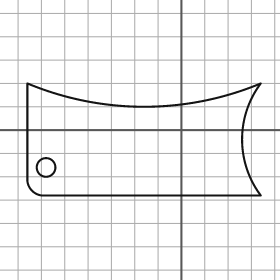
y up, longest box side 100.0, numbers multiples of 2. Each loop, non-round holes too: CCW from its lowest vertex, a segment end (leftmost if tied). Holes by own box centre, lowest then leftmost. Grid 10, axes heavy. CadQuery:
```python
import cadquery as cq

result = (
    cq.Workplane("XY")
    .moveTo(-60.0, -28.0)
    .lineTo(34.0, -28.0)
    .threePointArc((26.0, -4.0), (34.0, 20.0))
    .threePointArc((-16.0, 10.0), (-66.0, 20.0))
    .lineTo(-66.0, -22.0)
    .threePointArc((-64.0, -26.0), (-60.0, -28.0))
    .close()
    .moveTo(-58.0, -16.0)
    .circle(4.0)
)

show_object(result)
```